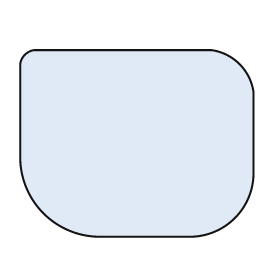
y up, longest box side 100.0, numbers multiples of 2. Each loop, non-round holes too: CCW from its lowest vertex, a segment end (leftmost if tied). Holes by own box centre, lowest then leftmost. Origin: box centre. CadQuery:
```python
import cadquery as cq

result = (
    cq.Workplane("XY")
    .moveTo(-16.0, -40.0)
    .lineTo(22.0, -40.0)
    .threePointArc((42.0, -32.0), (50.0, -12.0))
    .lineTo(50.0, 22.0)
    .threePointArc((44.0, 34.0), (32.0, 40.0))
    .lineTo(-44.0, 40.0)
    .threePointArc((-48.0, 38.0), (-50.0, 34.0))
    .lineTo(-50.0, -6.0)
    .threePointArc((-40.0, -30.0), (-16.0, -40.0))
    .close()
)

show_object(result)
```